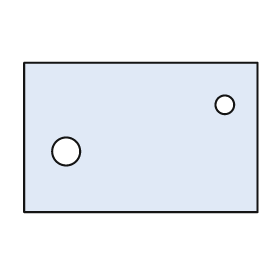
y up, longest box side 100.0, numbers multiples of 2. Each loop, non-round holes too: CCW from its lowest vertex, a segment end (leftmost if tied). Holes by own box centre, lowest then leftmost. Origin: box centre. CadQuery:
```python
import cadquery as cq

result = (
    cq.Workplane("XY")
    .moveTo(-50.0, -32.0)
    .lineTo(50.0, -32.0)
    .lineTo(50.0, 32.0)
    .lineTo(-50.0, 32.0)
    .close()
    .moveTo(-32.0, -6.0)
    .circle(6.0)
    .moveTo(36.0, 14.0)
    .circle(4.0)
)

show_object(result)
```